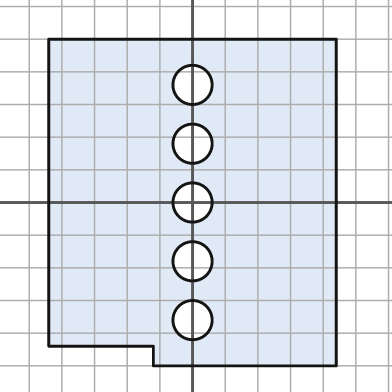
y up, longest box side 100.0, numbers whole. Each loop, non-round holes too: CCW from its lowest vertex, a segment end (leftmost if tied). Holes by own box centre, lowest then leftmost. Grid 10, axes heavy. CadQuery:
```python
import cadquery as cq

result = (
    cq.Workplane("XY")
    .moveTo(-12.0, -50.0)
    .lineTo(44.0, -50.0)
    .lineTo(44.0, 50.0)
    .lineTo(-44.0, 50.0)
    .lineTo(-44.0, -44.0)
    .lineTo(-12.0, -44.0)
    .close()
    .moveTo(0.0, -36.0)
    .circle(6.0)
    .moveTo(0.0, -18.0)
    .circle(6.0)
    .moveTo(0.0, 0.0)
    .circle(6.0)
    .moveTo(0.0, 18.0)
    .circle(6.0)
    .moveTo(0.0, 36.0)
    .circle(6.0)
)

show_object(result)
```